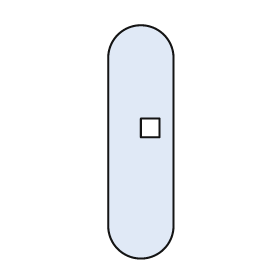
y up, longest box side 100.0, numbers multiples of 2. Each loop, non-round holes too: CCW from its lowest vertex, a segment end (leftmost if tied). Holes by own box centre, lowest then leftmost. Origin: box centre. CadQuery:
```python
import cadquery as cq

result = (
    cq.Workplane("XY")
    .moveTo(-14.0, -36.0)
    .threePointArc((0.0, -50.0), (14.0, -36.0))
    .lineTo(14.0, 36.0)
    .threePointArc((0.0, 50.0), (-14.0, 36.0))
    .close()
    .moveTo(0.0, 2.0)
    .lineTo(8.0, 2.0)
    .lineTo(8.0, 10.0)
    .lineTo(0.0, 10.0)
    .close()
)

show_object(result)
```